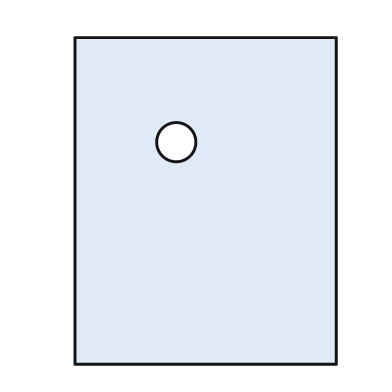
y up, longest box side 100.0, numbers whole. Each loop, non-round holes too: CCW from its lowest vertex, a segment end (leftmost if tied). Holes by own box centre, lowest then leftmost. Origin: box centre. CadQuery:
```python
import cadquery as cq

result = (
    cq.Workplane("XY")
    .moveTo(-40.0, -50.0)
    .lineTo(40.0, -50.0)
    .lineTo(40.0, 50.0)
    .lineTo(-40.0, 50.0)
    .close()
    .moveTo(-9.0, 18.0)
    .circle(6.0)
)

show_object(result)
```